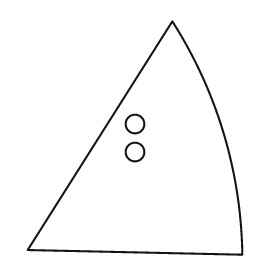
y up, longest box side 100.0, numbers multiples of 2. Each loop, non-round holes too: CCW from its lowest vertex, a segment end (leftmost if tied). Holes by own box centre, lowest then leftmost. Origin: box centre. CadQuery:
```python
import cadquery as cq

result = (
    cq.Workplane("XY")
    .moveTo(46.0, -50.0)
    .threePointArc((38.0, 2.0), (16.0, 50.0))
    .lineTo(-46.0, -48.0)
    .close()
    .moveTo(0.0, -6.0)
    .circle(4.0)
    .moveTo(0.0, 6.0)
    .circle(4.0)
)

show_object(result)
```